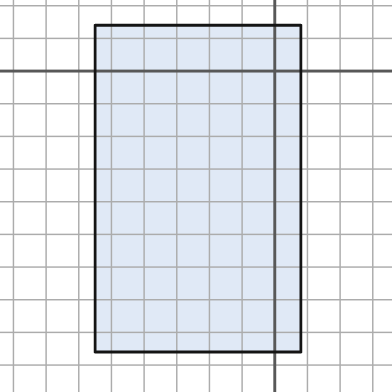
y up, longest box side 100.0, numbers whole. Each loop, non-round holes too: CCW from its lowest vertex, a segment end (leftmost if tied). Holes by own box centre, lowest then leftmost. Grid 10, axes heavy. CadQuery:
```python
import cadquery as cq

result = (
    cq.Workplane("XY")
    .moveTo(-55.0, -86.0)
    .lineTo(8.0, -86.0)
    .lineTo(8.0, 14.0)
    .lineTo(-55.0, 14.0)
    .close()
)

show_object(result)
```